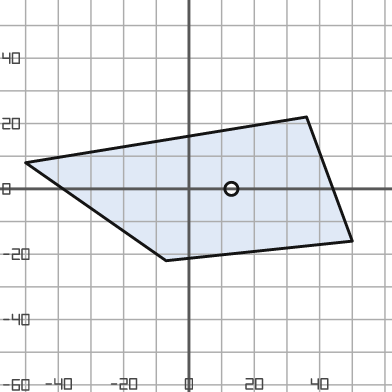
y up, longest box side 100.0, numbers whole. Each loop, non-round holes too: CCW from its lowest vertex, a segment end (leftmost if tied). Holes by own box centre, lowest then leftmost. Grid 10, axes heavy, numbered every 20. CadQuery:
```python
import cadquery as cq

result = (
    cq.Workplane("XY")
    .moveTo(-7.0, -22.0)
    .lineTo(50.0, -16.0)
    .lineTo(36.0, 22.0)
    .lineTo(-50.0, 8.0)
    .close()
    .moveTo(13.0, 0.0)
    .circle(2.0)
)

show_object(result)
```